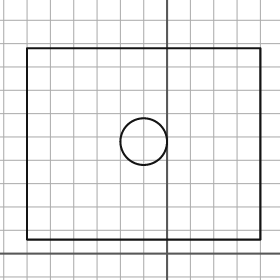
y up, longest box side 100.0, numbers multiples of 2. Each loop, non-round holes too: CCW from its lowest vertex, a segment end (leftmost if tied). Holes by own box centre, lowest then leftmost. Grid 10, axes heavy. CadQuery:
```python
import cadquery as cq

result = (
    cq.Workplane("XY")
    .moveTo(-60.0, 6.0)
    .lineTo(40.0, 6.0)
    .lineTo(40.0, 88.0)
    .lineTo(-60.0, 88.0)
    .close()
    .moveTo(-10.0, 48.0)
    .circle(10.0)
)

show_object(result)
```